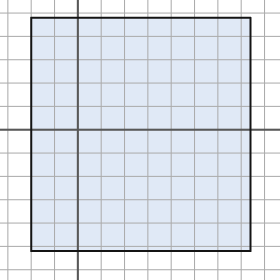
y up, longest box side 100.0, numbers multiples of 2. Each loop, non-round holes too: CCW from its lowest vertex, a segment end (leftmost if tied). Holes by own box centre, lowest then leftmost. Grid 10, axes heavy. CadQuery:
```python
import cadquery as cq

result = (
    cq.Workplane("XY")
    .moveTo(-20.0, -52.0)
    .lineTo(74.0, -52.0)
    .lineTo(74.0, 48.0)
    .lineTo(-20.0, 48.0)
    .close()
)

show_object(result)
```